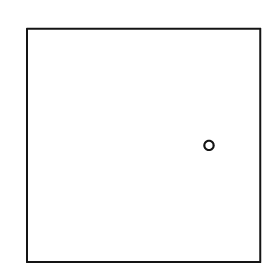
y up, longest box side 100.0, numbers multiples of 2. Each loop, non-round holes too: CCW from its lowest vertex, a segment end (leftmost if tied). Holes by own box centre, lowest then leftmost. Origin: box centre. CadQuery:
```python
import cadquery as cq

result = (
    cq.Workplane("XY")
    .moveTo(-50.0, -50.0)
    .lineTo(50.0, -50.0)
    .lineTo(50.0, 50.0)
    .lineTo(-50.0, 50.0)
    .close()
    .moveTo(28.0, 0.0)
    .circle(2.0)
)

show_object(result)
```